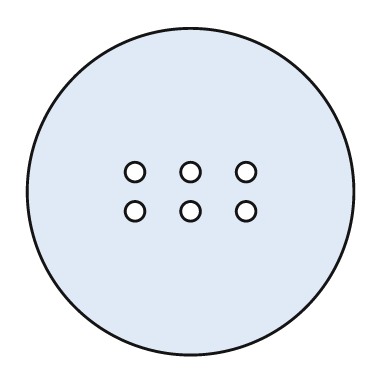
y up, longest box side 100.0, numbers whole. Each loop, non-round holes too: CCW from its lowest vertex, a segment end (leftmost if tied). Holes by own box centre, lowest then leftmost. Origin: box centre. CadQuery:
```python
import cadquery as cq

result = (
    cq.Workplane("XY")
    .moveTo(0.0, 0.0)
    .circle(50.0)
    .moveTo(-17.0, -6.0)
    .circle(3.0)
    .moveTo(0.0, -6.0)
    .circle(3.0)
    .moveTo(17.0, -6.0)
    .circle(3.0)
    .moveTo(-17.0, 6.0)
    .circle(3.0)
    .moveTo(0.0, 6.0)
    .circle(3.0)
    .moveTo(17.0, 6.0)
    .circle(3.0)
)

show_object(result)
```